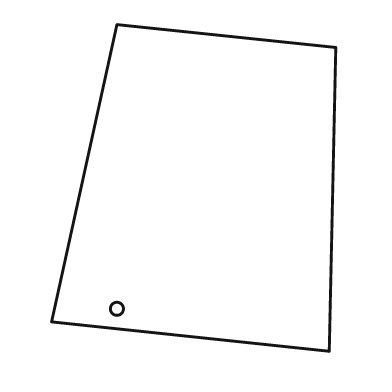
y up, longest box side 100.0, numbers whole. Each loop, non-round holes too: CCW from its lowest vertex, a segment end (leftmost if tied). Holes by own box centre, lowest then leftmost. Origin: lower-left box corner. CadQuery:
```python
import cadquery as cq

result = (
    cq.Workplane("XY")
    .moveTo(85.0, 0.0)
    .lineTo(87.0, 93.0)
    .lineTo(20.0, 100.0)
    .lineTo(0.0, 9.0)
    .close()
    .moveTo(20.0, 13.0)
    .circle(2.0)
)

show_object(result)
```